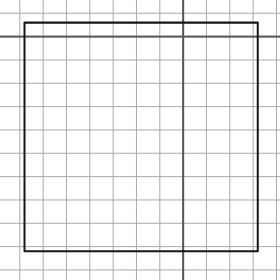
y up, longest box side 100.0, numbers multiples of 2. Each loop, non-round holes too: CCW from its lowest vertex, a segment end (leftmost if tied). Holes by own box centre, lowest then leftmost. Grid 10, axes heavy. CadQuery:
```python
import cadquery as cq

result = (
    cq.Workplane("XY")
    .moveTo(-68.0, -92.0)
    .lineTo(32.0, -92.0)
    .lineTo(32.0, 6.0)
    .lineTo(-68.0, 6.0)
    .close()
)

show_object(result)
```